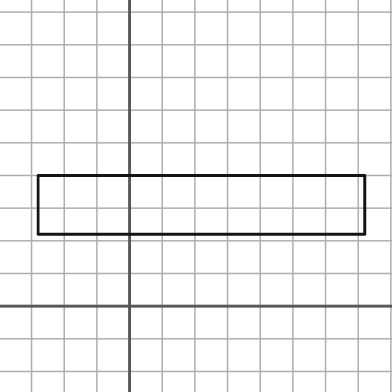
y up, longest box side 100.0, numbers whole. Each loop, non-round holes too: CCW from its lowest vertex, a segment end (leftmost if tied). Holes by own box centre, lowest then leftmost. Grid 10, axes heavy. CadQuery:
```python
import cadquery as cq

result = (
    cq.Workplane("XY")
    .moveTo(-28.0, 22.0)
    .lineTo(72.0, 22.0)
    .lineTo(72.0, 40.0)
    .lineTo(-28.0, 40.0)
    .close()
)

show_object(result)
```